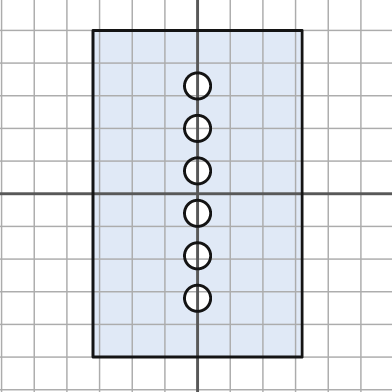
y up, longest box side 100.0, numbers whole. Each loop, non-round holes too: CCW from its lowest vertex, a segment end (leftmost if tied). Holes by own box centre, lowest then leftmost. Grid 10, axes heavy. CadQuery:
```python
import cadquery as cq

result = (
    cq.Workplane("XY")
    .moveTo(-32.0, -50.0)
    .lineTo(32.0, -50.0)
    .lineTo(32.0, 50.0)
    .lineTo(-32.0, 50.0)
    .close()
    .moveTo(0.0, -32.0)
    .circle(4.0)
    .moveTo(0.0, -19.0)
    .circle(4.0)
    .moveTo(0.0, -6.0)
    .circle(4.0)
    .moveTo(0.0, 7.0)
    .circle(4.0)
    .moveTo(0.0, 20.0)
    .circle(4.0)
    .moveTo(0.0, 33.0)
    .circle(4.0)
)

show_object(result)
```